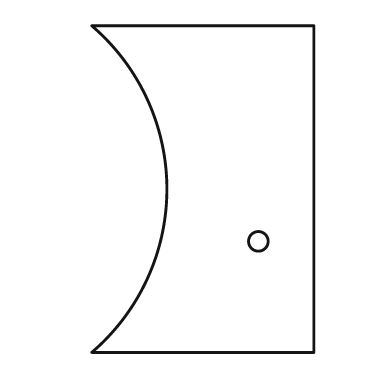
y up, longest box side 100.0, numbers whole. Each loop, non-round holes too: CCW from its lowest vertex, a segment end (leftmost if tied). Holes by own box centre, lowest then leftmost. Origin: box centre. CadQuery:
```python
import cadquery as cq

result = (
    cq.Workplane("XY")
    .moveTo(-34.0, -50.0)
    .lineTo(34.0, -50.0)
    .lineTo(34.0, 50.0)
    .lineTo(-34.0, 50.0)
    .threePointArc((-11.0, 0.0), (-34.0, -50.0))
    .close()
    .moveTo(17.0, -16.0)
    .circle(3.0)
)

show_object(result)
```